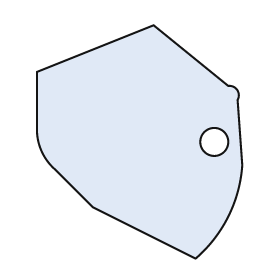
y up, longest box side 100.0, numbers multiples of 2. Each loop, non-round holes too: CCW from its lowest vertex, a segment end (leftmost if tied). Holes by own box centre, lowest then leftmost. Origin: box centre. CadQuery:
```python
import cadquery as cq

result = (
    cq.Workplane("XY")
    .moveTo(24.0, -50.0)
    .threePointArc((38.0, -32.0), (44.0, -10.0))
    .lineTo(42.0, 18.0)
    .threePointArc((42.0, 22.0), (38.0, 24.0))
    .lineTo(6.0, 50.0)
    .lineTo(-44.0, 30.0)
    .lineTo(-44.0, 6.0)
    .threePointArc((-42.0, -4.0), (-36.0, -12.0))
    .lineTo(-20.0, -28.0)
    .close()
    .moveTo(32.0, 0.0)
    .circle(6.0)
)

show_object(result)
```